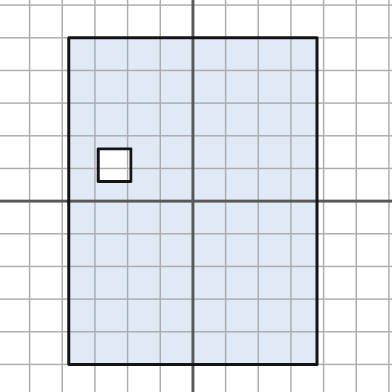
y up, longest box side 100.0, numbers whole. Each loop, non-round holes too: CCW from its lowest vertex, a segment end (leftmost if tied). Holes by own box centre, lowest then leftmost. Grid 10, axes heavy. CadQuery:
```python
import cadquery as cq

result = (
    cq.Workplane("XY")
    .moveTo(-38.0, -50.0)
    .lineTo(38.0, -50.0)
    .lineTo(38.0, 50.0)
    .lineTo(-38.0, 50.0)
    .close()
    .moveTo(-29.0, 6.0)
    .lineTo(-19.0, 6.0)
    .lineTo(-19.0, 16.0)
    .lineTo(-29.0, 16.0)
    .close()
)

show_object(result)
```